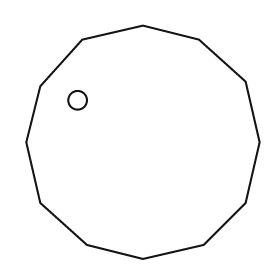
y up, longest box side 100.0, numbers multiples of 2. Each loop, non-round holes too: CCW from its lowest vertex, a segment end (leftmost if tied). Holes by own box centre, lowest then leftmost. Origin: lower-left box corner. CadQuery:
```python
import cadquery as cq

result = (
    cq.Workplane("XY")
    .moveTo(50.0, 0.0)
    .lineTo(76.0, 6.0)
    .lineTo(94.0, 24.0)
    .lineTo(100.0, 50.0)
    .lineTo(94.0, 76.0)
    .lineTo(74.0, 94.0)
    .lineTo(50.0, 100.0)
    .lineTo(24.0, 94.0)
    .lineTo(6.0, 74.0)
    .lineTo(0.0, 50.0)
    .lineTo(6.0, 24.0)
    .lineTo(26.0, 6.0)
    .close()
    .moveTo(22.0, 68.0)
    .circle(4.0)
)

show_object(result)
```